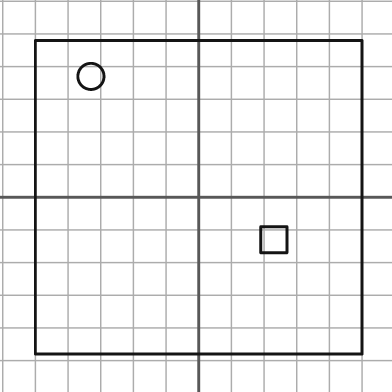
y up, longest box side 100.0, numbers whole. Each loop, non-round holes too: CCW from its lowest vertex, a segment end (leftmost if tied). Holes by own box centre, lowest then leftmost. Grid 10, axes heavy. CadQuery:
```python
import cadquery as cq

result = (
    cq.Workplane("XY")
    .moveTo(-50.0, -48.0)
    .lineTo(50.0, -48.0)
    .lineTo(50.0, 48.0)
    .lineTo(-50.0, 48.0)
    .close()
    .moveTo(19.0, -17.0)
    .lineTo(27.0, -17.0)
    .lineTo(27.0, -9.0)
    .lineTo(19.0, -9.0)
    .close()
    .moveTo(-33.0, 37.0)
    .circle(4.0)
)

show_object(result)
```